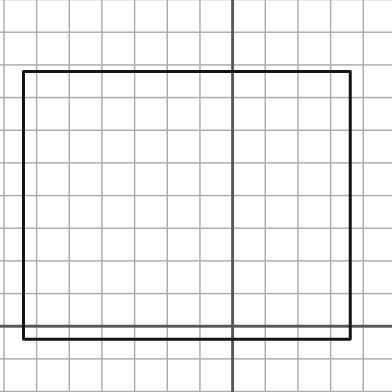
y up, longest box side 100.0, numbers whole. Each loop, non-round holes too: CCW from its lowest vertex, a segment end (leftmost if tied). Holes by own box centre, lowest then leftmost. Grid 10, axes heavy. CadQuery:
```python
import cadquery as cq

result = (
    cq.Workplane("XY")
    .moveTo(-64.0, -4.0)
    .lineTo(36.0, -4.0)
    .lineTo(36.0, 78.0)
    .lineTo(-64.0, 78.0)
    .close()
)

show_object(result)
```